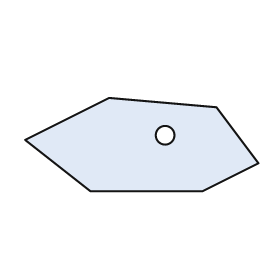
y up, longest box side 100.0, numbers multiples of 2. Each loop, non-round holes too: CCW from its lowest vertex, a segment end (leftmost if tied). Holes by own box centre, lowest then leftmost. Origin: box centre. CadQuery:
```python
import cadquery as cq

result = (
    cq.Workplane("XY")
    .moveTo(-22.0, -20.0)
    .lineTo(26.0, -20.0)
    .lineTo(50.0, -8.0)
    .lineTo(32.0, 16.0)
    .lineTo(-14.0, 20.0)
    .lineTo(-50.0, 2.0)
    .close()
    .moveTo(10.0, 4.0)
    .circle(4.0)
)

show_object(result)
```